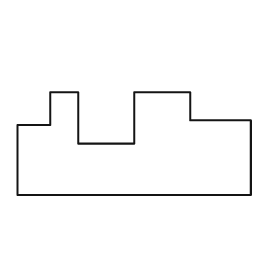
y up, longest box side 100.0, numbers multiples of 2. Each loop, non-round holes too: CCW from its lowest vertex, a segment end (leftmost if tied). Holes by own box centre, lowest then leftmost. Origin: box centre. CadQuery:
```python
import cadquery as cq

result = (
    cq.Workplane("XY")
    .moveTo(-50.0, -22.0)
    .lineTo(50.0, -22.0)
    .lineTo(50.0, 10.0)
    .lineTo(24.0, 10.0)
    .lineTo(24.0, 22.0)
    .lineTo(0.0, 22.0)
    .lineTo(0.0, 0.0)
    .lineTo(-24.0, 0.0)
    .lineTo(-24.0, 22.0)
    .lineTo(-36.0, 22.0)
    .lineTo(-36.0, 8.0)
    .lineTo(-50.0, 8.0)
    .close()
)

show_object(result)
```